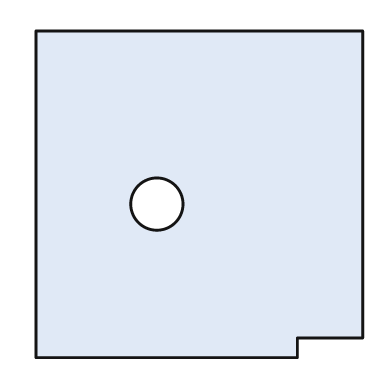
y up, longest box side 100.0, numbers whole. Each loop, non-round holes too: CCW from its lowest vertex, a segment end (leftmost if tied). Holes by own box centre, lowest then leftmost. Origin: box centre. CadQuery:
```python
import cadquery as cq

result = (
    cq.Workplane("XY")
    .moveTo(-50.0, -50.0)
    .lineTo(30.0, -50.0)
    .lineTo(30.0, -44.0)
    .lineTo(50.0, -44.0)
    .lineTo(50.0, 50.0)
    .lineTo(-50.0, 50.0)
    .close()
    .moveTo(-13.0, -3.0)
    .circle(8.0)
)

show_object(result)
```